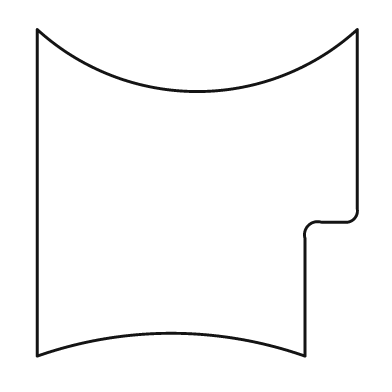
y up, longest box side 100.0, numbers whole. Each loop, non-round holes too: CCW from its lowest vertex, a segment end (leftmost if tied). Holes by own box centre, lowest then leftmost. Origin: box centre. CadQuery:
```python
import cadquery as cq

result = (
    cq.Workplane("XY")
    .moveTo(-49.0, -50.0)
    .threePointArc((-8.0, -43.0), (33.0, -50.0))
    .lineTo(33.0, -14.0)
    .threePointArc((34.0, -10.0), (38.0, -9.0))
    .lineTo(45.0, -9.0)
    .threePointArc((48.0, -8.0), (49.0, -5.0))
    .lineTo(49.0, 50.0)
    .threePointArc((0.0, 31.0), (-49.0, 50.0))
    .close()
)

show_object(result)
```